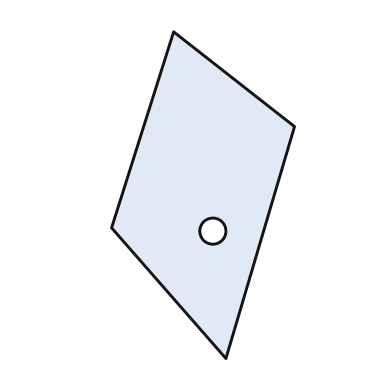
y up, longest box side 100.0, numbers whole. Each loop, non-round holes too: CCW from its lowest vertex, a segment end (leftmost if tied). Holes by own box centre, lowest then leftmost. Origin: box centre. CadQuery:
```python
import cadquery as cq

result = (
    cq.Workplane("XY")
    .moveTo(7.0, -50.0)
    .lineTo(28.0, 21.0)
    .lineTo(-9.0, 50.0)
    .lineTo(-28.0, -10.0)
    .close()
    .moveTo(3.0, -11.0)
    .circle(4.0)
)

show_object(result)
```